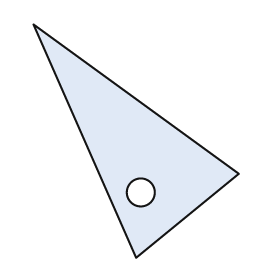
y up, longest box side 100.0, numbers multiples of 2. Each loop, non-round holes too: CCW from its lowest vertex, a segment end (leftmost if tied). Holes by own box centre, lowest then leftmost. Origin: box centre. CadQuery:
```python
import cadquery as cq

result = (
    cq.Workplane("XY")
    .moveTo(0.0, -50.0)
    .lineTo(44.0, -14.0)
    .lineTo(-44.0, 50.0)
    .close()
    .moveTo(2.0, -22.0)
    .circle(6.0)
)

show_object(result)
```